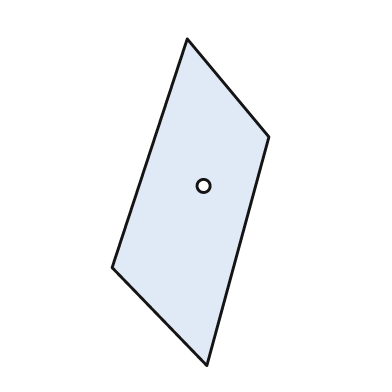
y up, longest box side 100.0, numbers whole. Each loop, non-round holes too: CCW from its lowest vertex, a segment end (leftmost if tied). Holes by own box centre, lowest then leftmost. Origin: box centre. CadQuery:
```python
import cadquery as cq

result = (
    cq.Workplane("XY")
    .moveTo(5.0, -50.0)
    .lineTo(24.0, 20.0)
    .lineTo(-1.0, 50.0)
    .lineTo(-24.0, -20.0)
    .close()
    .moveTo(4.0, 5.0)
    .circle(2.0)
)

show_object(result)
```